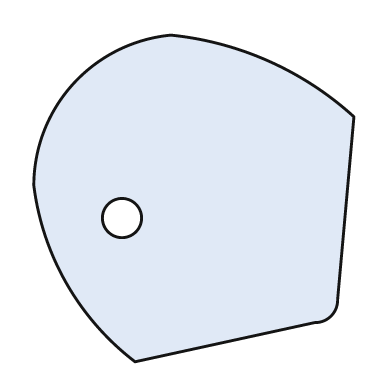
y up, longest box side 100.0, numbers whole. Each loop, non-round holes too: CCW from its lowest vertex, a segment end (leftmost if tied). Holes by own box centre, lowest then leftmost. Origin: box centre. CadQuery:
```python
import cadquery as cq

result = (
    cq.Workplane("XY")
    .moveTo(-18.0, -50.0)
    .lineTo(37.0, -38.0)
    .threePointArc((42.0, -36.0), (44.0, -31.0))
    .lineTo(49.0, 25.0)
    .threePointArc((23.0, 42.0), (-7.0, 50.0))
    .threePointArc((-37.0, 35.0), (-49.0, 4.0))
    .threePointArc((-39.0, -26.0), (-18.0, -50.0))
    .close()
    .moveTo(-22.0, -6.0)
    .circle(6.0)
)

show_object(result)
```